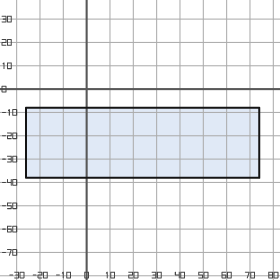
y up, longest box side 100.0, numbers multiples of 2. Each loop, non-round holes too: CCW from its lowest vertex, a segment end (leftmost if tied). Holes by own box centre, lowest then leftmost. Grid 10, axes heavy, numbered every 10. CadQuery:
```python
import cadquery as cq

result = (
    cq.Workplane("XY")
    .moveTo(-26.0, -38.0)
    .lineTo(74.0, -38.0)
    .lineTo(74.0, -8.0)
    .lineTo(-26.0, -8.0)
    .close()
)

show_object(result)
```